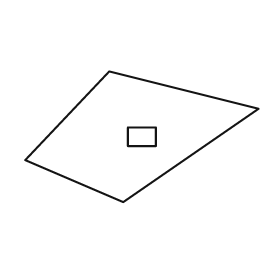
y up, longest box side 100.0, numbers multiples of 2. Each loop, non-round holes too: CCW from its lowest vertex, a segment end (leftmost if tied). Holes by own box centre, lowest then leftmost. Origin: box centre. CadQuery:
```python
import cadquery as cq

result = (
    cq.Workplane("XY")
    .moveTo(-8.0, -28.0)
    .lineTo(50.0, 12.0)
    .lineTo(-14.0, 28.0)
    .lineTo(-50.0, -10.0)
    .close()
    .moveTo(-6.0, -4.0)
    .lineTo(6.0, -4.0)
    .lineTo(6.0, 4.0)
    .lineTo(-6.0, 4.0)
    .close()
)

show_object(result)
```